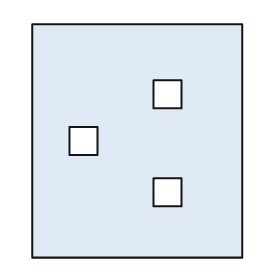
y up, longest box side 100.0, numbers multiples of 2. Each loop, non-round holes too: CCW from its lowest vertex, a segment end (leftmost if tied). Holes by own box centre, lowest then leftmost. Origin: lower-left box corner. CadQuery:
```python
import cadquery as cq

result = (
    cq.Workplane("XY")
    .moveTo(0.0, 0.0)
    .lineTo(90.0, 0.0)
    .lineTo(90.0, 100.0)
    .lineTo(0.0, 100.0)
    .close()
    .moveTo(52.0, 22.0)
    .lineTo(64.0, 22.0)
    .lineTo(64.0, 34.0)
    .lineTo(52.0, 34.0)
    .close()
    .moveTo(16.0, 44.0)
    .lineTo(28.0, 44.0)
    .lineTo(28.0, 56.0)
    .lineTo(16.0, 56.0)
    .close()
    .moveTo(52.0, 64.0)
    .lineTo(64.0, 64.0)
    .lineTo(64.0, 76.0)
    .lineTo(52.0, 76.0)
    .close()
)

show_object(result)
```